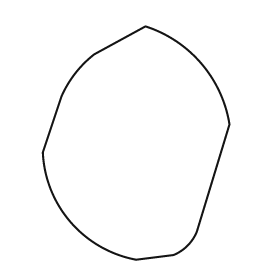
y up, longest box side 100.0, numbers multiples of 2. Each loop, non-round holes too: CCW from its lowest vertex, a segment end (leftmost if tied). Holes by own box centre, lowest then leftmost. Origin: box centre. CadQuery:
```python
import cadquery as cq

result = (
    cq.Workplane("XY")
    .moveTo(0.0, -50.0)
    .lineTo(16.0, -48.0)
    .threePointArc((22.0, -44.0), (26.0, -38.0))
    .lineTo(40.0, 8.0)
    .threePointArc((28.0, 34.0), (4.0, 50.0))
    .lineTo(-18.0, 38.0)
    .threePointArc((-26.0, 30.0), (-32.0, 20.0))
    .lineTo(-40.0, -4.0)
    .threePointArc((-28.0, -34.0), (0.0, -50.0))
    .close()
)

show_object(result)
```